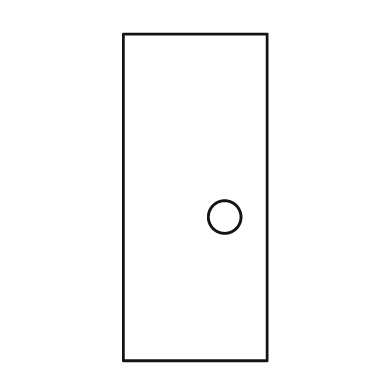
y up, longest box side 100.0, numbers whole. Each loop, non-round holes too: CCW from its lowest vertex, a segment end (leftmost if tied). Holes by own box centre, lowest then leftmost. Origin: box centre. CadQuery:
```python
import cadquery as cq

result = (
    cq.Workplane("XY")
    .moveTo(-22.0, -50.0)
    .lineTo(22.0, -50.0)
    .lineTo(22.0, 50.0)
    .lineTo(-22.0, 50.0)
    .close()
    .moveTo(9.0, -6.0)
    .circle(5.0)
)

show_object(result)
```